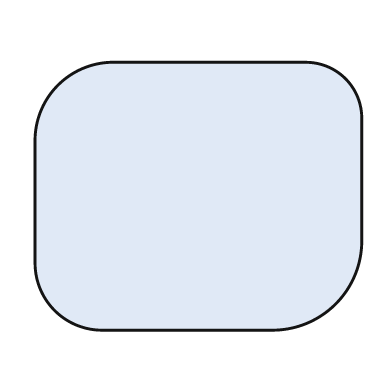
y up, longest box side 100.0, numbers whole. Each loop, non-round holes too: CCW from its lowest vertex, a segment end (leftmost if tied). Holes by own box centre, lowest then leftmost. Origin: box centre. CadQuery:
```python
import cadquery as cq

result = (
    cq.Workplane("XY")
    .moveTo(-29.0, -41.0)
    .lineTo(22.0, -41.0)
    .threePointArc((42.0, -33.0), (50.0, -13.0))
    .lineTo(50.0, 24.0)
    .threePointArc((45.0, 36.0), (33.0, 41.0))
    .lineTo(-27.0, 41.0)
    .threePointArc((-43.0, 34.0), (-50.0, 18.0))
    .lineTo(-50.0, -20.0)
    .threePointArc((-44.0, -35.0), (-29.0, -41.0))
    .close()
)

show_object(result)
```